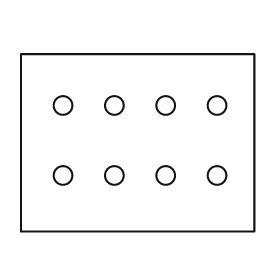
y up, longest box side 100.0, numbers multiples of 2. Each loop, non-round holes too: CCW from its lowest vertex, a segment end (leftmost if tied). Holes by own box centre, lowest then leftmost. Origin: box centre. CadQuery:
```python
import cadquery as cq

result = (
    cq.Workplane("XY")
    .moveTo(-50.0, -38.0)
    .lineTo(50.0, -38.0)
    .lineTo(50.0, 38.0)
    .lineTo(-50.0, 38.0)
    .close()
    .moveTo(-32.0, -14.0)
    .circle(4.0)
    .moveTo(-10.0, -14.0)
    .circle(4.0)
    .moveTo(12.0, -14.0)
    .circle(4.0)
    .moveTo(34.0, -14.0)
    .circle(4.0)
    .moveTo(-32.0, 16.0)
    .circle(4.0)
    .moveTo(-10.0, 16.0)
    .circle(4.0)
    .moveTo(12.0, 16.0)
    .circle(4.0)
    .moveTo(34.0, 16.0)
    .circle(4.0)
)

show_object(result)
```